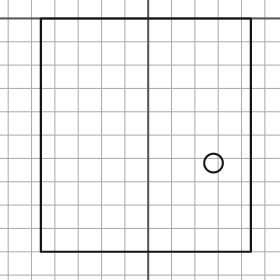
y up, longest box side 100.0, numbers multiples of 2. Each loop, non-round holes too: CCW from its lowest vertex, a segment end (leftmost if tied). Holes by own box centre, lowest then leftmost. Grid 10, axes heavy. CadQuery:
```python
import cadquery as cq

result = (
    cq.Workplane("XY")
    .moveTo(-46.0, -100.0)
    .lineTo(44.0, -100.0)
    .lineTo(44.0, 0.0)
    .lineTo(-46.0, 0.0)
    .close()
    .moveTo(28.0, -62.0)
    .circle(4.0)
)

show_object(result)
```